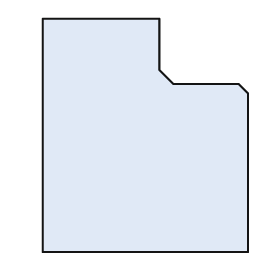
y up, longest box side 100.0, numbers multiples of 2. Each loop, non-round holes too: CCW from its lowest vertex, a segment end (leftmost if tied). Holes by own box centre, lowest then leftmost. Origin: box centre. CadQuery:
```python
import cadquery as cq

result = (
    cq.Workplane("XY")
    .moveTo(-44.0, -50.0)
    .lineTo(44.0, -50.0)
    .lineTo(44.0, 18.0)
    .lineTo(40.0, 22.0)
    .lineTo(12.0, 22.0)
    .lineTo(6.0, 28.0)
    .lineTo(6.0, 50.0)
    .lineTo(-44.0, 50.0)
    .close()
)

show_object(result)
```